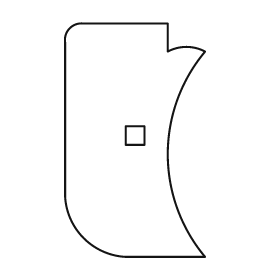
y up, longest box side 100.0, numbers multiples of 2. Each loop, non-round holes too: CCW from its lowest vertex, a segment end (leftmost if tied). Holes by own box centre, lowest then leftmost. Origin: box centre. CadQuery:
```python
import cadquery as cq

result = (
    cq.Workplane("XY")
    .moveTo(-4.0, -50.0)
    .lineTo(30.0, -50.0)
    .threePointArc((14.0, -6.0), (30.0, 38.0))
    .threePointArc((22.0, 40.0), (14.0, 38.0))
    .lineTo(14.0, 50.0)
    .lineTo(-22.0, 50.0)
    .threePointArc((-28.0, 48.0), (-30.0, 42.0))
    .lineTo(-30.0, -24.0)
    .threePointArc((-22.0, -42.0), (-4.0, -50.0))
    .close()
    .moveTo(-4.0, -2.0)
    .lineTo(4.0, -2.0)
    .lineTo(4.0, 6.0)
    .lineTo(-4.0, 6.0)
    .close()
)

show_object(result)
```